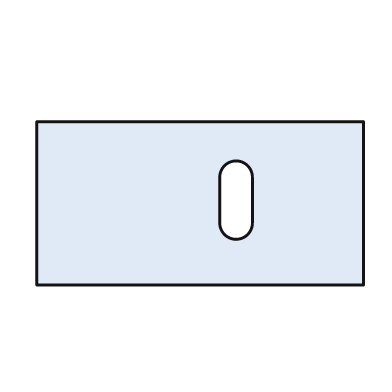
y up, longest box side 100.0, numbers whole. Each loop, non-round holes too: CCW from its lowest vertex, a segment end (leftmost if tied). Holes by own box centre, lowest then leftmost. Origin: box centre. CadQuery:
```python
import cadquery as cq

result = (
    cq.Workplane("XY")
    .moveTo(-50.0, -25.0)
    .lineTo(50.0, -25.0)
    .lineTo(50.0, 25.0)
    .lineTo(-50.0, 25.0)
    .close()
    .moveTo(6.0, -6.0)
    .threePointArc((11.0, -11.0), (16.0, -6.0))
    .lineTo(16.0, 8.0)
    .threePointArc((11.0, 13.0), (6.0, 8.0))
    .close()
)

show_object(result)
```